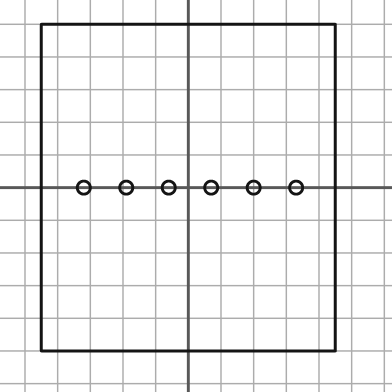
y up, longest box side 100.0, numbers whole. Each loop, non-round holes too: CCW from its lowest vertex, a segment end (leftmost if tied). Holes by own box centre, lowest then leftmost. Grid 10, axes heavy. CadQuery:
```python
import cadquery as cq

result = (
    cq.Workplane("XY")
    .moveTo(-45.0, -50.0)
    .lineTo(45.0, -50.0)
    .lineTo(45.0, 50.0)
    .lineTo(-45.0, 50.0)
    .close()
    .moveTo(-32.0, 0.0)
    .circle(2.0)
    .moveTo(-19.0, 0.0)
    .circle(2.0)
    .moveTo(-6.0, 0.0)
    .circle(2.0)
    .moveTo(7.0, 0.0)
    .circle(2.0)
    .moveTo(20.0, 0.0)
    .circle(2.0)
    .moveTo(33.0, 0.0)
    .circle(2.0)
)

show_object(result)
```